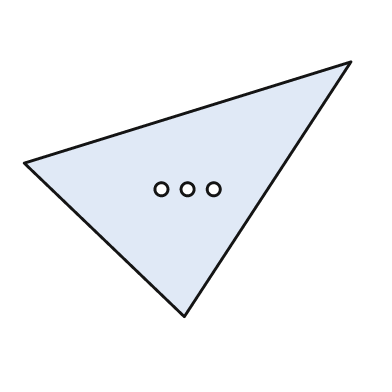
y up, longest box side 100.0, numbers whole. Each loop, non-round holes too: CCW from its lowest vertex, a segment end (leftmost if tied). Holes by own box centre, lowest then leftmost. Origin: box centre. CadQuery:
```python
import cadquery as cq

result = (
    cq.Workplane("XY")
    .moveTo(-1.0, -39.0)
    .lineTo(50.0, 39.0)
    .lineTo(-50.0, 8.0)
    .close()
    .moveTo(-8.0, 0.0)
    .circle(2.0)
    .moveTo(0.0, 0.0)
    .circle(2.0)
    .moveTo(8.0, 0.0)
    .circle(2.0)
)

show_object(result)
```